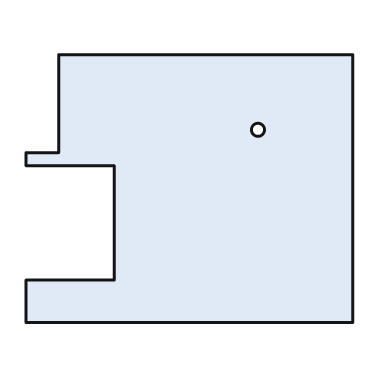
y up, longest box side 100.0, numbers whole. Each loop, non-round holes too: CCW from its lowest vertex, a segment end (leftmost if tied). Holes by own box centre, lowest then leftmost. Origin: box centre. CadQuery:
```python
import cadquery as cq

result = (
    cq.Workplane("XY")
    .moveTo(-50.0, -41.0)
    .lineTo(50.0, -41.0)
    .lineTo(50.0, 41.0)
    .lineTo(-40.0, 41.0)
    .lineTo(-40.0, 11.0)
    .lineTo(-50.0, 11.0)
    .lineTo(-50.0, 7.0)
    .lineTo(-23.0, 7.0)
    .lineTo(-23.0, -28.0)
    .lineTo(-50.0, -28.0)
    .close()
    .moveTo(21.0, 18.0)
    .circle(2.0)
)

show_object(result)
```